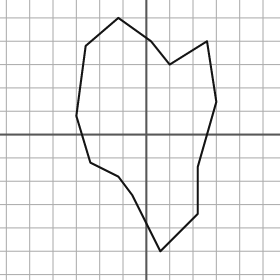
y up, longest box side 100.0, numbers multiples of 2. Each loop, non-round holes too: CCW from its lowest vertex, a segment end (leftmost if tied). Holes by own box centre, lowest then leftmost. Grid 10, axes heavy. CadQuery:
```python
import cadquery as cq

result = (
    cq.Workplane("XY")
    .moveTo(6.0, -50.0)
    .lineTo(22.0, -34.0)
    .lineTo(22.0, -14.0)
    .lineTo(30.0, 14.0)
    .lineTo(26.0, 40.0)
    .lineTo(10.0, 30.0)
    .lineTo(2.0, 40.0)
    .lineTo(-12.0, 50.0)
    .lineTo(-26.0, 38.0)
    .lineTo(-30.0, 8.0)
    .lineTo(-24.0, -12.0)
    .lineTo(-12.0, -18.0)
    .lineTo(-6.0, -26.0)
    .close()
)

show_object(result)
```